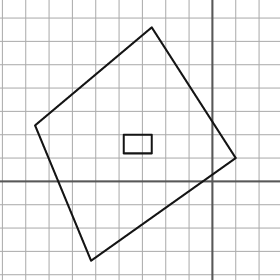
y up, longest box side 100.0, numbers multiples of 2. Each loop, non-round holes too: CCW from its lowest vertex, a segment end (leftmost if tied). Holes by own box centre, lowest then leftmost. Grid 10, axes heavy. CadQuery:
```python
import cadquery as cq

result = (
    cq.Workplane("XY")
    .moveTo(-52.0, -34.0)
    .lineTo(10.0, 10.0)
    .lineTo(-26.0, 66.0)
    .lineTo(-76.0, 24.0)
    .close()
    .moveTo(-38.0, 12.0)
    .lineTo(-26.0, 12.0)
    .lineTo(-26.0, 20.0)
    .lineTo(-38.0, 20.0)
    .close()
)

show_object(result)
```